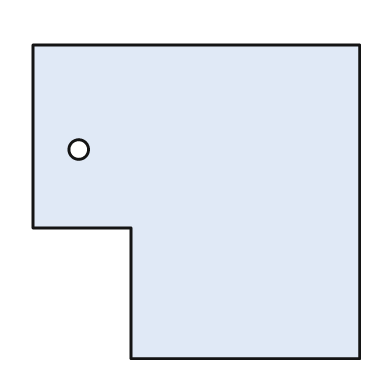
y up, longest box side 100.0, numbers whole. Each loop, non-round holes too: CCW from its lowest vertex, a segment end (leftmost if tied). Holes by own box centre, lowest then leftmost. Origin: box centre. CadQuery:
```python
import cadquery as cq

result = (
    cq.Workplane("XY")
    .moveTo(-20.0, -48.0)
    .lineTo(50.0, -48.0)
    .lineTo(50.0, 48.0)
    .lineTo(-50.0, 48.0)
    .lineTo(-50.0, -8.0)
    .lineTo(-20.0, -8.0)
    .close()
    .moveTo(-36.0, 16.0)
    .circle(3.0)
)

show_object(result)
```